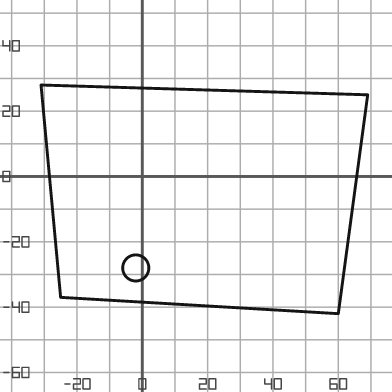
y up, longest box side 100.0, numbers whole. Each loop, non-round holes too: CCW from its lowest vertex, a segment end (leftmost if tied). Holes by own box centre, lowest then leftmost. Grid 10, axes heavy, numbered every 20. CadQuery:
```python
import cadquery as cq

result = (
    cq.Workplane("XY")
    .moveTo(60.0, -42.0)
    .lineTo(69.0, 25.0)
    .lineTo(-31.0, 28.0)
    .lineTo(-25.0, -37.0)
    .close()
    .moveTo(-2.0, -28.0)
    .circle(4.0)
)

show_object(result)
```